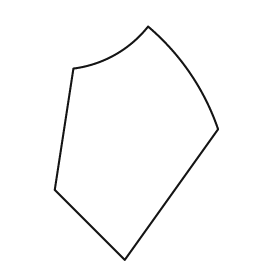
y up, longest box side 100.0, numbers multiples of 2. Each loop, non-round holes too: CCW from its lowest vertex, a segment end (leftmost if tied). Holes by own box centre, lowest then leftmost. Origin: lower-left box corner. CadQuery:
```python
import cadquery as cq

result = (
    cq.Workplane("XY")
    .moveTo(30.0, 0.0)
    .lineTo(70.0, 56.0)
    .threePointArc((58.0, 80.0), (40.0, 100.0))
    .threePointArc((26.0, 88.0), (8.0, 82.0))
    .lineTo(0.0, 30.0)
    .close()
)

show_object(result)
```